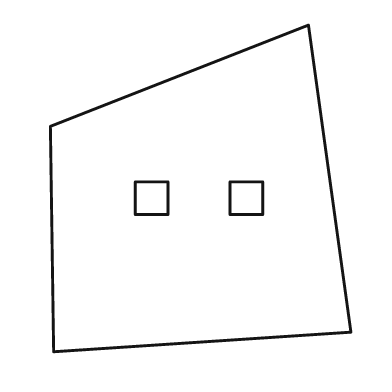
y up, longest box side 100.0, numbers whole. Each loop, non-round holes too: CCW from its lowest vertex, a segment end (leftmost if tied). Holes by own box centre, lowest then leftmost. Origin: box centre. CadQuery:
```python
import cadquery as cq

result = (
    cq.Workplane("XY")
    .moveTo(-45.0, -50.0)
    .lineTo(46.0, -44.0)
    .lineTo(33.0, 50.0)
    .lineTo(-46.0, 19.0)
    .close()
    .moveTo(-20.0, -8.0)
    .lineTo(-10.0, -8.0)
    .lineTo(-10.0, 2.0)
    .lineTo(-20.0, 2.0)
    .close()
    .moveTo(9.0, -8.0)
    .lineTo(19.0, -8.0)
    .lineTo(19.0, 2.0)
    .lineTo(9.0, 2.0)
    .close()
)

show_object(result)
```